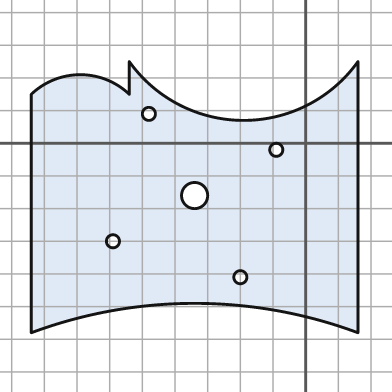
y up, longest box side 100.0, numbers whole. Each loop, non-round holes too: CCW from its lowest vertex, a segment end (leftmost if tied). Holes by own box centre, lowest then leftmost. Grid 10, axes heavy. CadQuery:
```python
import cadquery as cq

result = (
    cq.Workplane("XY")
    .moveTo(-84.0, -58.0)
    .threePointArc((-34.0, -49.0), (16.0, -58.0))
    .lineTo(16.0, 25.0)
    .threePointArc((-19.0, 7.0), (-54.0, 25.0))
    .lineTo(-54.0, 15.0)
    .threePointArc((-69.0, 21.0), (-84.0, 15.0))
    .close()
    .moveTo(-20.0, -41.0)
    .circle(2.0)
    .moveTo(-59.0, -30.0)
    .circle(2.0)
    .moveTo(-34.0, -16.0)
    .circle(4.0)
    .moveTo(-9.0, -2.0)
    .circle(2.0)
    .moveTo(-48.0, 9.0)
    .circle(2.0)
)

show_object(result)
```